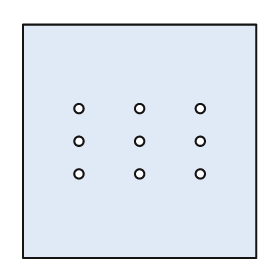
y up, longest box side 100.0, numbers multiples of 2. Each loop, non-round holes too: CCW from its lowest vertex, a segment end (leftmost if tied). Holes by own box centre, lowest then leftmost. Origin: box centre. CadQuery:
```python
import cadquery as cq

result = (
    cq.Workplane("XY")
    .moveTo(-50.0, -50.0)
    .lineTo(50.0, -50.0)
    .lineTo(50.0, 50.0)
    .lineTo(-50.0, 50.0)
    .close()
    .moveTo(-26.0, -14.0)
    .circle(2.0)
    .moveTo(0.0, -14.0)
    .circle(2.0)
    .moveTo(26.0, -14.0)
    .circle(2.0)
    .moveTo(-26.0, 0.0)
    .circle(2.0)
    .moveTo(0.0, 0.0)
    .circle(2.0)
    .moveTo(26.0, 0.0)
    .circle(2.0)
    .moveTo(-26.0, 14.0)
    .circle(2.0)
    .moveTo(0.0, 14.0)
    .circle(2.0)
    .moveTo(26.0, 14.0)
    .circle(2.0)
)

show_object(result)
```